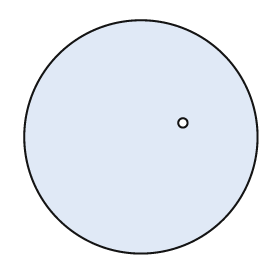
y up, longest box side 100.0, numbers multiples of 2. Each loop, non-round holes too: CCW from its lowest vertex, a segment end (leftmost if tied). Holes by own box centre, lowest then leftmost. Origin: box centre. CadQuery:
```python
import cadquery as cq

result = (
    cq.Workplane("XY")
    .moveTo(0.0, 0.0)
    .circle(50.0)
    .moveTo(18.0, 6.0)
    .circle(2.0)
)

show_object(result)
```